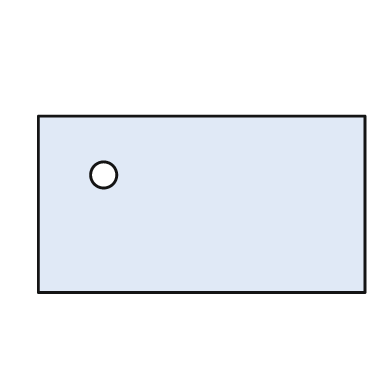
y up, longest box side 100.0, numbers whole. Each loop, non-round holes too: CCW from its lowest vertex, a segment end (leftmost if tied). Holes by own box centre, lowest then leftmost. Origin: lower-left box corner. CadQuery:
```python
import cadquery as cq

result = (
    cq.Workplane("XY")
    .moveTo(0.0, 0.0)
    .lineTo(100.0, 0.0)
    .lineTo(100.0, 54.0)
    .lineTo(0.0, 54.0)
    .close()
    .moveTo(20.0, 36.0)
    .circle(4.0)
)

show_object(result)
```